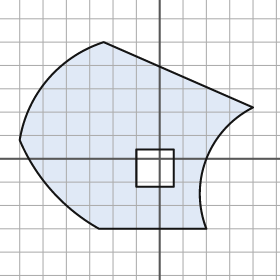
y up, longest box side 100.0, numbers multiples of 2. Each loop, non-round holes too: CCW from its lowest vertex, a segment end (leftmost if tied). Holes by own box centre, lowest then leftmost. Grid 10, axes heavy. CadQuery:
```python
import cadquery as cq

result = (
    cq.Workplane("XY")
    .moveTo(-26.0, -30.0)
    .lineTo(20.0, -30.0)
    .threePointArc((20.0, 0.0), (40.0, 22.0))
    .lineTo(-24.0, 50.0)
    .threePointArc((-48.0, 34.0), (-60.0, 8.0))
    .threePointArc((-46.0, -14.0), (-26.0, -30.0))
    .close()
    .moveTo(-10.0, -12.0)
    .lineTo(6.0, -12.0)
    .lineTo(6.0, 4.0)
    .lineTo(-10.0, 4.0)
    .close()
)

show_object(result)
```